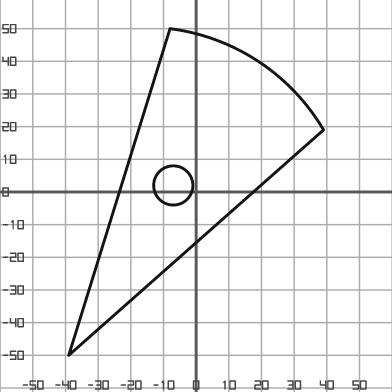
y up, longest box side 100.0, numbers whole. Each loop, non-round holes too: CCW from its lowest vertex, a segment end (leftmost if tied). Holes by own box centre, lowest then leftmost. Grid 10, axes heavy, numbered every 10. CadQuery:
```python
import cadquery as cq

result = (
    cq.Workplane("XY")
    .moveTo(-39.0, -50.0)
    .lineTo(39.0, 19.0)
    .threePointArc((19.0, 40.0), (-8.0, 50.0))
    .close()
    .moveTo(-7.0, 2.0)
    .circle(6.0)
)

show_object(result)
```